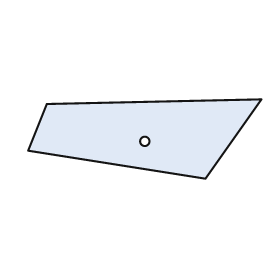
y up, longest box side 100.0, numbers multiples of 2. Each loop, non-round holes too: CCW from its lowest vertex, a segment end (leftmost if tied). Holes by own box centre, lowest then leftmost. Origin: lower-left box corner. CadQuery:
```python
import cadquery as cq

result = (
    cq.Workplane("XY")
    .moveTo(76.0, 0.0)
    .lineTo(100.0, 34.0)
    .lineTo(8.0, 32.0)
    .lineTo(0.0, 12.0)
    .close()
    .moveTo(50.0, 16.0)
    .circle(2.0)
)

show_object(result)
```